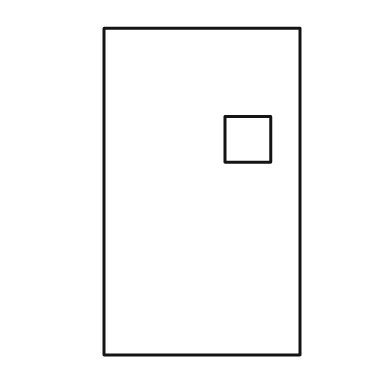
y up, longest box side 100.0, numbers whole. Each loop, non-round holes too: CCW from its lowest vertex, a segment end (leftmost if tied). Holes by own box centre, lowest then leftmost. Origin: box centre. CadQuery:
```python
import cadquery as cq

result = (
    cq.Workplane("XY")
    .moveTo(-30.0, -50.0)
    .lineTo(30.0, -50.0)
    .lineTo(30.0, 50.0)
    .lineTo(-30.0, 50.0)
    .close()
    .moveTo(7.0, 9.0)
    .lineTo(21.0, 9.0)
    .lineTo(21.0, 23.0)
    .lineTo(7.0, 23.0)
    .close()
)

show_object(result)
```